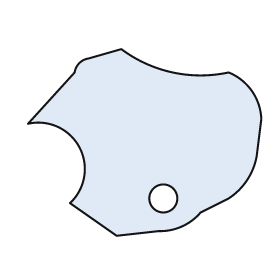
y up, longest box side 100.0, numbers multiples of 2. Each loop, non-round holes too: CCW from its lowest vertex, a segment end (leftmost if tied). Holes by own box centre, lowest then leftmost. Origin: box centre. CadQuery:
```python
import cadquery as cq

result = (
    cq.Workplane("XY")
    .moveTo(-12.0, -40.0)
    .lineTo(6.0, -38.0)
    .threePointArc((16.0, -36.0), (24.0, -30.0))
    .lineTo(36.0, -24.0)
    .threePointArc((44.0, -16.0), (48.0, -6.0))
    .lineTo(50.0, 10.0)
    .threePointArc((46.0, 22.0), (36.0, 30.0))
    .threePointArc((12.0, 30.0), (-10.0, 40.0))
    .lineTo(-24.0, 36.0)
    .threePointArc((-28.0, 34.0), (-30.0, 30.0))
    .lineTo(-50.0, 8.0)
    .threePointArc((-28.0, -2.0), (-32.0, -26.0))
    .close()
    .moveTo(8.0, -24.0)
    .circle(6.0)
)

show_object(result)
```